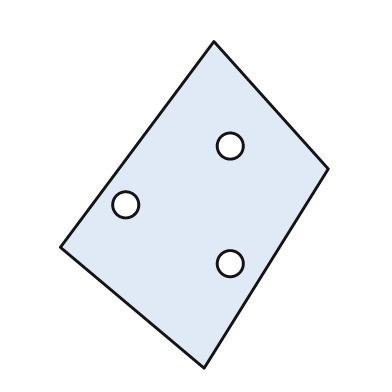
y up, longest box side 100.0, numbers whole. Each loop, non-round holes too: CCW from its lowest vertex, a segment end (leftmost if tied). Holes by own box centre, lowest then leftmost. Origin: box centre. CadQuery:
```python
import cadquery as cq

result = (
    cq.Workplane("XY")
    .moveTo(3.0, -50.0)
    .lineTo(41.0, 11.0)
    .lineTo(6.0, 50.0)
    .lineTo(-41.0, -13.0)
    .close()
    .moveTo(11.0, -18.0)
    .circle(4.0)
    .moveTo(-21.0, 0.0)
    .circle(4.0)
    .moveTo(11.0, 18.0)
    .circle(4.0)
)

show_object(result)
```